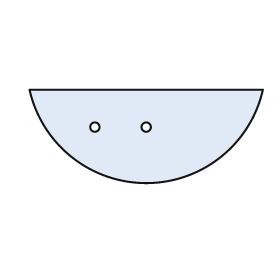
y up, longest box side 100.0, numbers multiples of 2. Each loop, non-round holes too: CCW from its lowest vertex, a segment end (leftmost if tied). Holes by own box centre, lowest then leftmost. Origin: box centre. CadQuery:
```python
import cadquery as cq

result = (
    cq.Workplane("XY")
    .moveTo(-50.0, 20.0)
    .threePointArc((0.0, -20.0), (50.0, 20.0))
    .close()
    .moveTo(-22.0, 4.0)
    .circle(2.0)
    .moveTo(0.0, 4.0)
    .circle(2.0)
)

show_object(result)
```